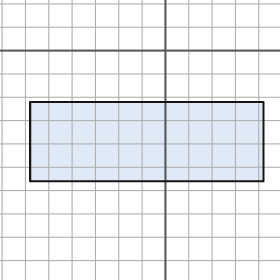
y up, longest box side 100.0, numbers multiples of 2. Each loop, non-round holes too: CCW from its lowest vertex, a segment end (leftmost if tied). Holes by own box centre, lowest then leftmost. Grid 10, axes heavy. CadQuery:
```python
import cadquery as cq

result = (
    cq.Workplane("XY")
    .moveTo(-58.0, -56.0)
    .lineTo(42.0, -56.0)
    .lineTo(42.0, -22.0)
    .lineTo(-58.0, -22.0)
    .close()
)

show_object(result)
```